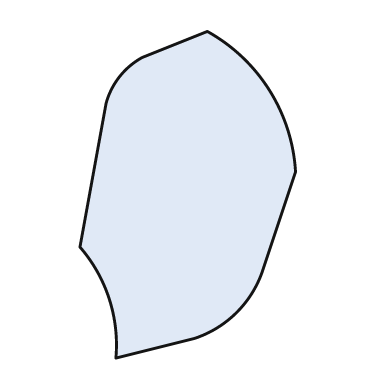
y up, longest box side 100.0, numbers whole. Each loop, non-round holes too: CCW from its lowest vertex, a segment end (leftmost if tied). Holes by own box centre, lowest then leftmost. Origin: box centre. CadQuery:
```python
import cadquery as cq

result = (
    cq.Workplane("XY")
    .moveTo(-22.0, -50.0)
    .lineTo(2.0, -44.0)
    .threePointArc((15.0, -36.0), (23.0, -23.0))
    .lineTo(33.0, 7.0)
    .threePointArc((25.0, 32.0), (6.0, 50.0))
    .lineTo(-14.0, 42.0)
    .threePointArc((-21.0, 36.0), (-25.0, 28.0))
    .lineTo(-33.0, -16.0)
    .threePointArc((-24.0, -32.0), (-22.0, -50.0))
    .close()
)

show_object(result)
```